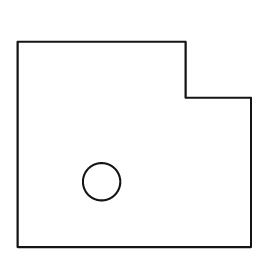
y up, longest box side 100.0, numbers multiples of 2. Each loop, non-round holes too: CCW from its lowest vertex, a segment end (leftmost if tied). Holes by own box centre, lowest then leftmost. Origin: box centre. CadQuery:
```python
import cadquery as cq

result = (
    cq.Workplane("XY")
    .moveTo(-50.0, -44.0)
    .lineTo(50.0, -44.0)
    .lineTo(50.0, 20.0)
    .lineTo(22.0, 20.0)
    .lineTo(22.0, 44.0)
    .lineTo(-50.0, 44.0)
    .close()
    .moveTo(-14.0, -16.0)
    .circle(8.0)
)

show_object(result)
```